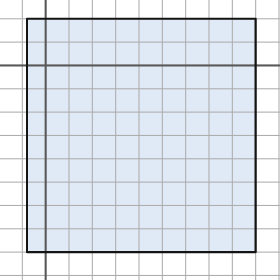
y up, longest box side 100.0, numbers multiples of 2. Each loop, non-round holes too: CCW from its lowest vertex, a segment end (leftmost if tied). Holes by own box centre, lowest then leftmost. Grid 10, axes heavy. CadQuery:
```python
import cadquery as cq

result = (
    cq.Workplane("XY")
    .moveTo(-8.0, -80.0)
    .lineTo(90.0, -80.0)
    .lineTo(90.0, 20.0)
    .lineTo(-8.0, 20.0)
    .close()
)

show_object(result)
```